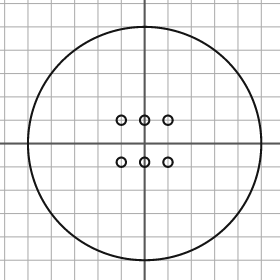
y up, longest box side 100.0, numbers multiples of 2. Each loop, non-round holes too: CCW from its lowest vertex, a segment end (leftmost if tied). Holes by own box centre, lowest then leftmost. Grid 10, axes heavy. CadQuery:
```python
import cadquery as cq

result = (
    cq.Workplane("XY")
    .moveTo(0.0, 0.0)
    .circle(50.0)
    .moveTo(-10.0, -8.0)
    .circle(2.0)
    .moveTo(0.0, -8.0)
    .circle(2.0)
    .moveTo(10.0, -8.0)
    .circle(2.0)
    .moveTo(-10.0, 10.0)
    .circle(2.0)
    .moveTo(0.0, 10.0)
    .circle(2.0)
    .moveTo(10.0, 10.0)
    .circle(2.0)
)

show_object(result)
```